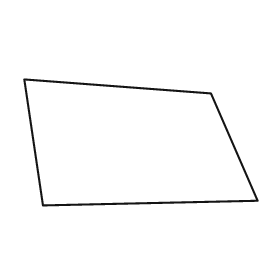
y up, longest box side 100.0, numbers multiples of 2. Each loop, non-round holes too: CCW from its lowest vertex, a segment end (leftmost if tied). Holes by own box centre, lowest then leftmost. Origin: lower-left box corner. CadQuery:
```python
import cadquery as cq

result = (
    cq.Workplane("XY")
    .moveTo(8.0, 0.0)
    .lineTo(100.0, 2.0)
    .lineTo(80.0, 48.0)
    .lineTo(0.0, 54.0)
    .close()
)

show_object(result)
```